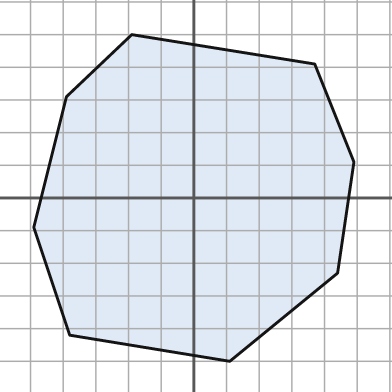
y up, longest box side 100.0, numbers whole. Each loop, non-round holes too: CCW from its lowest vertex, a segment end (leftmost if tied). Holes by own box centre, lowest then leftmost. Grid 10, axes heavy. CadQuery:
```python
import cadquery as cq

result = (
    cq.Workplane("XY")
    .moveTo(11.0, -50.0)
    .lineTo(44.0, -23.0)
    .lineTo(49.0, 11.0)
    .lineTo(37.0, 41.0)
    .lineTo(-19.0, 50.0)
    .lineTo(-39.0, 31.0)
    .lineTo(-49.0, -9.0)
    .lineTo(-38.0, -42.0)
    .close()
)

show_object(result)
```